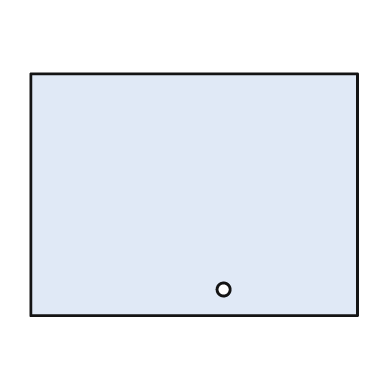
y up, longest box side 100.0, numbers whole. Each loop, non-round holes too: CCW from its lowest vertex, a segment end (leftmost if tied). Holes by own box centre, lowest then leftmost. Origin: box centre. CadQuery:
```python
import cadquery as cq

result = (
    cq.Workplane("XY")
    .moveTo(-50.0, -37.0)
    .lineTo(50.0, -37.0)
    .lineTo(50.0, 37.0)
    .lineTo(-50.0, 37.0)
    .close()
    .moveTo(9.0, -29.0)
    .circle(2.0)
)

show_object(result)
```